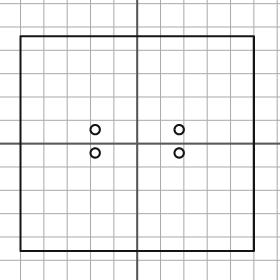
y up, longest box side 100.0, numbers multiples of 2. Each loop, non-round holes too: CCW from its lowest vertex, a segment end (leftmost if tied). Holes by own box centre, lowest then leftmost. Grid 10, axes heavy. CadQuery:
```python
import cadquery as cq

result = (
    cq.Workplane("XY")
    .moveTo(-50.0, -46.0)
    .lineTo(50.0, -46.0)
    .lineTo(50.0, 46.0)
    .lineTo(-50.0, 46.0)
    .close()
    .moveTo(-18.0, -4.0)
    .circle(2.0)
    .moveTo(18.0, -4.0)
    .circle(2.0)
    .moveTo(-18.0, 6.0)
    .circle(2.0)
    .moveTo(18.0, 6.0)
    .circle(2.0)
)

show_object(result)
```